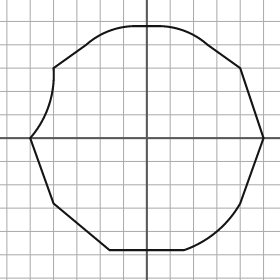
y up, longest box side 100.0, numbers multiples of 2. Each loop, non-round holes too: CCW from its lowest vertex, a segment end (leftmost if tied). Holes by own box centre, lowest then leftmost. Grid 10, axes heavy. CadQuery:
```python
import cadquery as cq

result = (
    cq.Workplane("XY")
    .moveTo(-16.0, -48.0)
    .lineTo(16.0, -48.0)
    .threePointArc((30.0, -40.0), (40.0, -28.0))
    .lineTo(50.0, 0.0)
    .lineTo(40.0, 30.0)
    .lineTo(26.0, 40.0)
    .threePointArc((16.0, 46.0), (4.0, 48.0))
    .lineTo(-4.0, 48.0)
    .threePointArc((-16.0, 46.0), (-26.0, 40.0))
    .lineTo(-40.0, 30.0)
    .threePointArc((-42.0, 14.0), (-50.0, 0.0))
    .lineTo(-40.0, -28.0)
    .close()
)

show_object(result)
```